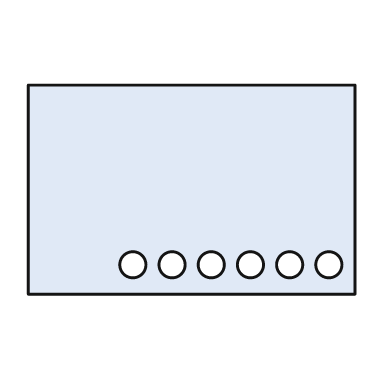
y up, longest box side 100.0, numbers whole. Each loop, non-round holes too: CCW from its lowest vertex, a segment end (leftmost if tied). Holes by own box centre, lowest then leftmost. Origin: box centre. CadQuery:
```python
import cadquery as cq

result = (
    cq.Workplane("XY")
    .moveTo(-50.0, -32.0)
    .lineTo(50.0, -32.0)
    .lineTo(50.0, 32.0)
    .lineTo(-50.0, 32.0)
    .close()
    .moveTo(-18.0, -23.0)
    .circle(4.0)
    .moveTo(-6.0, -23.0)
    .circle(4.0)
    .moveTo(6.0, -23.0)
    .circle(4.0)
    .moveTo(18.0, -23.0)
    .circle(4.0)
    .moveTo(30.0, -23.0)
    .circle(4.0)
    .moveTo(42.0, -23.0)
    .circle(4.0)
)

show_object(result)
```